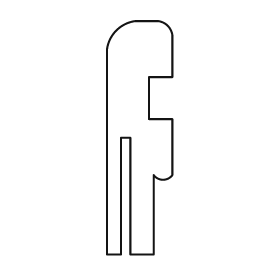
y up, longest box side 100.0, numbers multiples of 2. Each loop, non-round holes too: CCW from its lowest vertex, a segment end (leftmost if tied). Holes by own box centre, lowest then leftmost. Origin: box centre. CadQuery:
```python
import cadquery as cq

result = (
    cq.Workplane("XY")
    .moveTo(-14.0, -50.0)
    .lineTo(-8.0, -50.0)
    .lineTo(-8.0, 0.0)
    .lineTo(-4.0, 0.0)
    .lineTo(-4.0, -50.0)
    .lineTo(6.0, -50.0)
    .lineTo(6.0, -16.0)
    .threePointArc((10.0, -18.0), (14.0, -16.0))
    .lineTo(14.0, 8.0)
    .lineTo(4.0, 8.0)
    .lineTo(4.0, 26.0)
    .lineTo(14.0, 26.0)
    .lineTo(14.0, 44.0)
    .threePointArc((12.0, 48.0), (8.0, 50.0))
    .lineTo(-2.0, 50.0)
    .threePointArc((-10.0, 46.0), (-14.0, 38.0))
    .close()
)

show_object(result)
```